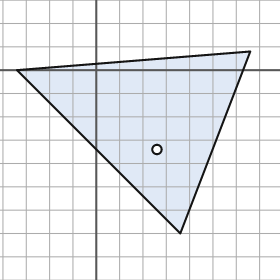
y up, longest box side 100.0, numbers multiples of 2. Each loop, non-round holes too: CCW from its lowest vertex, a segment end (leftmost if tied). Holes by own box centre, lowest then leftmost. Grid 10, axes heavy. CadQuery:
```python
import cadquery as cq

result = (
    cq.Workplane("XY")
    .moveTo(36.0, -70.0)
    .lineTo(66.0, 8.0)
    .lineTo(-34.0, 0.0)
    .close()
    .moveTo(26.0, -34.0)
    .circle(2.0)
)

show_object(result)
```